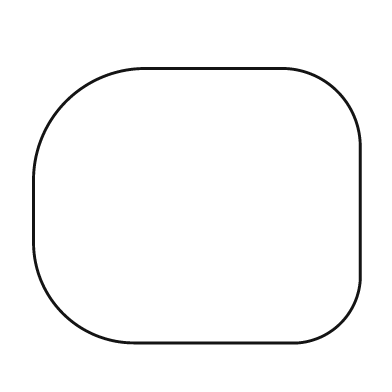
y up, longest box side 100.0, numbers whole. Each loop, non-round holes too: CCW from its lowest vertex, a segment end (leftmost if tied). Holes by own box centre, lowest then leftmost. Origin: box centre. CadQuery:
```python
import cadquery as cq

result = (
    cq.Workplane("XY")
    .moveTo(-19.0, -42.0)
    .lineTo(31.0, -42.0)
    .threePointArc((44.0, -36.0), (50.0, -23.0))
    .lineTo(50.0, 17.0)
    .threePointArc((43.0, 35.0), (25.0, 42.0))
    .lineTo(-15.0, 42.0)
    .threePointArc((-40.0, 32.0), (-50.0, 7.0))
    .lineTo(-50.0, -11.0)
    .threePointArc((-41.0, -33.0), (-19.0, -42.0))
    .close()
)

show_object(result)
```